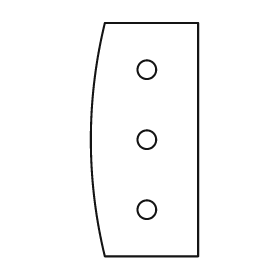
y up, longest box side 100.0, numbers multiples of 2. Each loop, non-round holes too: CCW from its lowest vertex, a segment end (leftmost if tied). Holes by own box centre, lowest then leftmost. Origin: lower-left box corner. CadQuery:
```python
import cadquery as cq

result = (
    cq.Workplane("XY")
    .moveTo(6.0, 0.0)
    .lineTo(46.0, 0.0)
    .lineTo(46.0, 100.0)
    .lineTo(6.0, 100.0)
    .threePointArc((0.0, 50.0), (6.0, 0.0))
    .close()
    .moveTo(24.0, 20.0)
    .circle(4.0)
    .moveTo(24.0, 50.0)
    .circle(4.0)
    .moveTo(24.0, 80.0)
    .circle(4.0)
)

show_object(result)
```